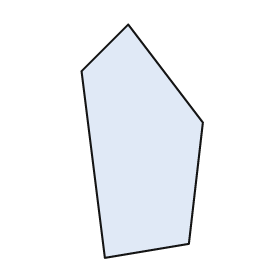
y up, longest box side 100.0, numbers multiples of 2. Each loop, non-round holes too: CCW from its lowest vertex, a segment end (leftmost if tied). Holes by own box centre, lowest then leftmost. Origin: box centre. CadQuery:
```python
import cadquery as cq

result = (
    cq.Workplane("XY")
    .moveTo(-16.0, -50.0)
    .lineTo(20.0, -44.0)
    .lineTo(26.0, 8.0)
    .lineTo(-6.0, 50.0)
    .lineTo(-26.0, 30.0)
    .close()
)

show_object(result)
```